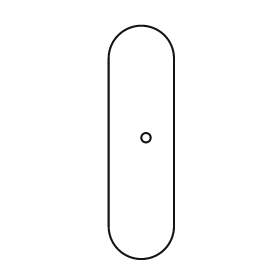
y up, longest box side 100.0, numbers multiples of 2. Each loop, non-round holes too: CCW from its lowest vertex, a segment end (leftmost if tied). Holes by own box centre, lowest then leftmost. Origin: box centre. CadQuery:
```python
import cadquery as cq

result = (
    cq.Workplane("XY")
    .moveTo(-14.0, -36.0)
    .threePointArc((0.0, -50.0), (14.0, -36.0))
    .lineTo(14.0, 36.0)
    .threePointArc((0.0, 50.0), (-14.0, 36.0))
    .close()
    .moveTo(2.0, 2.0)
    .circle(2.0)
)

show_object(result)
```